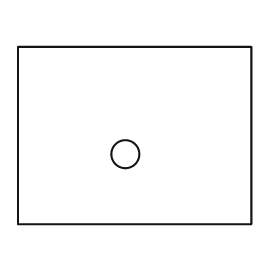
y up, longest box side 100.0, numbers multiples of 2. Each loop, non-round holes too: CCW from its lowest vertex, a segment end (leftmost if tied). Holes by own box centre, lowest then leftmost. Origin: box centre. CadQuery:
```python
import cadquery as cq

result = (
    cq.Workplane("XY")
    .moveTo(-50.0, -38.0)
    .lineTo(50.0, -38.0)
    .lineTo(50.0, 38.0)
    .lineTo(-50.0, 38.0)
    .close()
    .moveTo(-4.0, -8.0)
    .circle(6.0)
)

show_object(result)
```